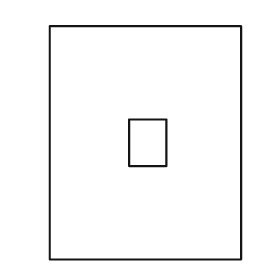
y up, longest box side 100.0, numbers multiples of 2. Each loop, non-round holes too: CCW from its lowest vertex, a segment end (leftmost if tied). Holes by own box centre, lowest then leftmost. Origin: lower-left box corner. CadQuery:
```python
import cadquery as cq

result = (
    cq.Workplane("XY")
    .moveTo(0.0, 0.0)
    .lineTo(82.0, 0.0)
    .lineTo(82.0, 100.0)
    .lineTo(0.0, 100.0)
    .close()
    .moveTo(34.0, 40.0)
    .lineTo(50.0, 40.0)
    .lineTo(50.0, 60.0)
    .lineTo(34.0, 60.0)
    .close()
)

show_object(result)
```